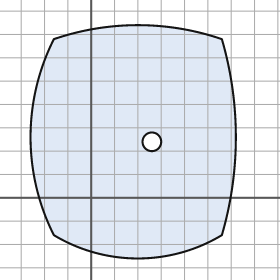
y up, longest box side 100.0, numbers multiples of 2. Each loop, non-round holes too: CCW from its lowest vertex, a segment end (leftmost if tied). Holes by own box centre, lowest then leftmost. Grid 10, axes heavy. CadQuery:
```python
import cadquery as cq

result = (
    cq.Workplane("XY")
    .moveTo(-16.0, -16.0)
    .threePointArc((20.0, -26.0), (56.0, -16.0))
    .threePointArc((62.0, 26.0), (56.0, 68.0))
    .threePointArc((20.0, 74.0), (-16.0, 68.0))
    .threePointArc((-26.0, 26.0), (-16.0, -16.0))
    .close()
    .moveTo(26.0, 24.0)
    .circle(4.0)
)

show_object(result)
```